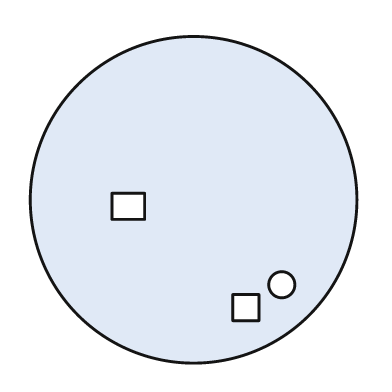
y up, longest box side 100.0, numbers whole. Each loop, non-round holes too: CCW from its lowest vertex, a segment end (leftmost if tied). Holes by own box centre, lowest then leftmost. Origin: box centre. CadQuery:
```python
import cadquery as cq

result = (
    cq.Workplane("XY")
    .moveTo(0.0, 0.0)
    .circle(50.0)
    .moveTo(12.0, -37.0)
    .lineTo(20.0, -37.0)
    .lineTo(20.0, -29.0)
    .lineTo(12.0, -29.0)
    .close()
    .moveTo(27.0, -26.0)
    .circle(4.0)
    .moveTo(-25.0, -6.0)
    .lineTo(-15.0, -6.0)
    .lineTo(-15.0, 2.0)
    .lineTo(-25.0, 2.0)
    .close()
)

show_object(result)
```